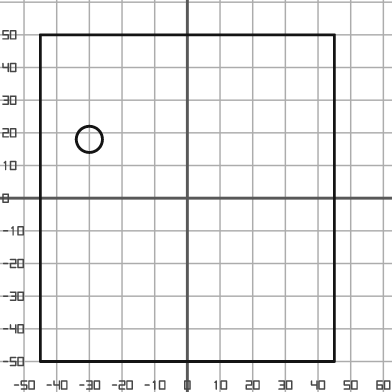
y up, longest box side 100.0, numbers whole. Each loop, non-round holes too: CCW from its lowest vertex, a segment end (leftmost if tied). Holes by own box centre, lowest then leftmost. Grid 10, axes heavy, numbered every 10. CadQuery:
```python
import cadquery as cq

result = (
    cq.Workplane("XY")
    .moveTo(-45.0, -50.0)
    .lineTo(45.0, -50.0)
    .lineTo(45.0, 50.0)
    .lineTo(-45.0, 50.0)
    .close()
    .moveTo(-30.0, 18.0)
    .circle(4.0)
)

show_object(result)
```